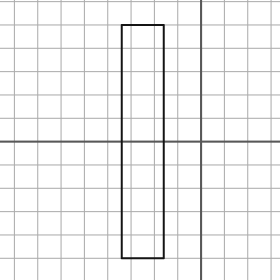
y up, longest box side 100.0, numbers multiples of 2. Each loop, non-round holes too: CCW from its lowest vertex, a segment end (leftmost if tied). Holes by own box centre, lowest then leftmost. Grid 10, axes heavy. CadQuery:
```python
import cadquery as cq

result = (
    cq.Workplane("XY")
    .moveTo(-34.0, -50.0)
    .lineTo(-16.0, -50.0)
    .lineTo(-16.0, 50.0)
    .lineTo(-34.0, 50.0)
    .close()
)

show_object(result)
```